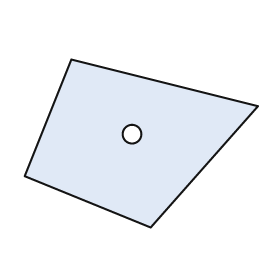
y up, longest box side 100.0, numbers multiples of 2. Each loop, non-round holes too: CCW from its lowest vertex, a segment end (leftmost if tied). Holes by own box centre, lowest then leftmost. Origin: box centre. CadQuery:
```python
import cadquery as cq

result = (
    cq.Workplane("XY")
    .moveTo(4.0, -36.0)
    .lineTo(50.0, 16.0)
    .lineTo(-30.0, 36.0)
    .lineTo(-50.0, -14.0)
    .close()
    .moveTo(-4.0, 4.0)
    .circle(4.0)
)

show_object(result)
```